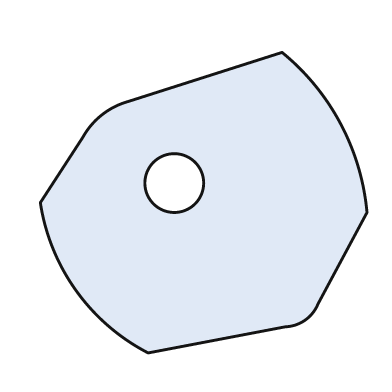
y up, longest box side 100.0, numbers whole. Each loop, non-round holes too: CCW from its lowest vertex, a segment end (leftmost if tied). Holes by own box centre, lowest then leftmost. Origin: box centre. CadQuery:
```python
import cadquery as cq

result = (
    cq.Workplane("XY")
    .moveTo(-17.0, -46.0)
    .lineTo(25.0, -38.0)
    .threePointArc((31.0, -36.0), (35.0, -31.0))
    .lineTo(50.0, -3.0)
    .threePointArc((42.0, 24.0), (24.0, 46.0))
    .lineTo(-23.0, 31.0)
    .threePointArc((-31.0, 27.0), (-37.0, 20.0))
    .lineTo(-50.0, 0.0)
    .threePointArc((-39.0, -27.0), (-17.0, -46.0))
    .close()
    .moveTo(-9.0, 6.0)
    .circle(9.0)
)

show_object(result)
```